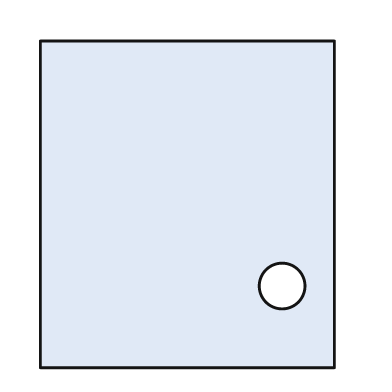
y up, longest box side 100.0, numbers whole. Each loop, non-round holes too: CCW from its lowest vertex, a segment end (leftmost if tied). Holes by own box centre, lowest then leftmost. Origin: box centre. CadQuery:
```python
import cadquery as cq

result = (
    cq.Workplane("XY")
    .moveTo(-45.0, -50.0)
    .lineTo(45.0, -50.0)
    .lineTo(45.0, 50.0)
    .lineTo(-45.0, 50.0)
    .close()
    .moveTo(29.0, -25.0)
    .circle(7.0)
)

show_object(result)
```